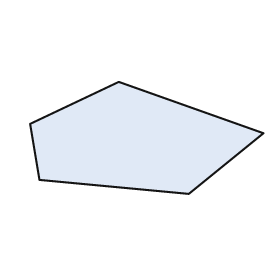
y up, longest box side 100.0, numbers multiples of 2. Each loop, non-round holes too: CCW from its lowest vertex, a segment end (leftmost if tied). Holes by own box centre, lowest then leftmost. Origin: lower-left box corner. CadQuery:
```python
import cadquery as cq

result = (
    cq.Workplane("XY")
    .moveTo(68.0, 0.0)
    .lineTo(100.0, 26.0)
    .lineTo(38.0, 48.0)
    .lineTo(0.0, 30.0)
    .lineTo(4.0, 6.0)
    .close()
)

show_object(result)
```